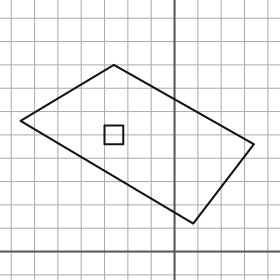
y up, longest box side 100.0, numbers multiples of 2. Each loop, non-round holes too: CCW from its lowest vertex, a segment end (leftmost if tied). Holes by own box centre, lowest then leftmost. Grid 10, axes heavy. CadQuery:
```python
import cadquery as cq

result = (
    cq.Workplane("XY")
    .moveTo(8.0, 12.0)
    .lineTo(34.0, 46.0)
    .lineTo(-26.0, 80.0)
    .lineTo(-66.0, 56.0)
    .close()
    .moveTo(-30.0, 46.0)
    .lineTo(-22.0, 46.0)
    .lineTo(-22.0, 54.0)
    .lineTo(-30.0, 54.0)
    .close()
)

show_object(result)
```